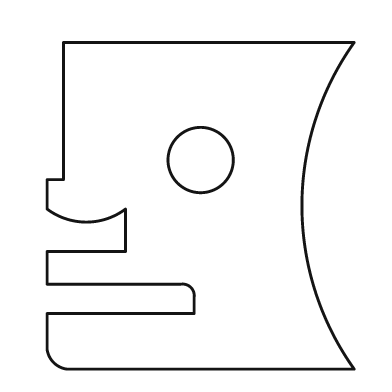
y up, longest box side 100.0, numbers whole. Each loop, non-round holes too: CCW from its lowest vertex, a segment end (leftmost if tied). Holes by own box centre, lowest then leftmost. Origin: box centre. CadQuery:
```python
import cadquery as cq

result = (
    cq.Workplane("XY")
    .moveTo(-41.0, -50.0)
    .lineTo(47.0, -50.0)
    .threePointArc((31.0, 0.0), (47.0, 50.0))
    .lineTo(-42.0, 50.0)
    .lineTo(-42.0, 8.0)
    .lineTo(-47.0, 8.0)
    .lineTo(-47.0, -1.0)
    .threePointArc((-35.0, -5.0), (-23.0, -1.0))
    .lineTo(-23.0, -14.0)
    .lineTo(-47.0, -14.0)
    .lineTo(-47.0, -24.0)
    .lineTo(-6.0, -24.0)
    .threePointArc((-3.0, -25.0), (-2.0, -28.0))
    .lineTo(-2.0, -33.0)
    .lineTo(-47.0, -33.0)
    .lineTo(-47.0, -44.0)
    .threePointArc((-45.0, -48.0), (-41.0, -50.0))
    .close()
    .moveTo(0.0, 14.0)
    .circle(10.0)
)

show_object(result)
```